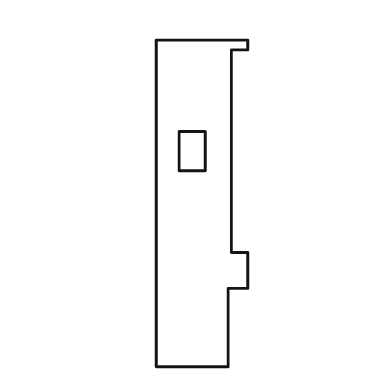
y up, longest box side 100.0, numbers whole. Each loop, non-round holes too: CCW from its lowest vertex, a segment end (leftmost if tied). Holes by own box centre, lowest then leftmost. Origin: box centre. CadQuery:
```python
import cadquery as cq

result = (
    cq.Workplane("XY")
    .moveTo(-14.0, -50.0)
    .lineTo(8.0, -50.0)
    .lineTo(8.0, -26.0)
    .lineTo(14.0, -26.0)
    .lineTo(14.0, -15.0)
    .lineTo(9.0, -15.0)
    .lineTo(9.0, 47.0)
    .lineTo(14.0, 47.0)
    .lineTo(14.0, 50.0)
    .lineTo(-14.0, 50.0)
    .close()
    .moveTo(-7.0, 10.0)
    .lineTo(1.0, 10.0)
    .lineTo(1.0, 22.0)
    .lineTo(-7.0, 22.0)
    .close()
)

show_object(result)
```